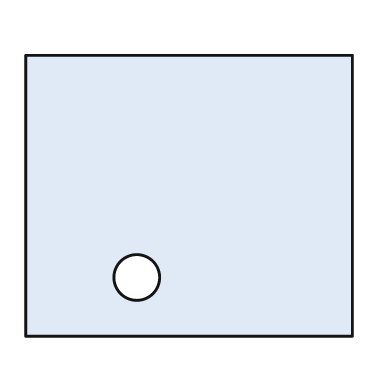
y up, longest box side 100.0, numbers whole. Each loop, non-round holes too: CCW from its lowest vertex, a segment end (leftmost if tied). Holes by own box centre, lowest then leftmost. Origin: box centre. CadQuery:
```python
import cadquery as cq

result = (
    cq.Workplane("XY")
    .moveTo(-50.0, -43.0)
    .lineTo(50.0, -43.0)
    .lineTo(50.0, 43.0)
    .lineTo(-50.0, 43.0)
    .close()
    .moveTo(-16.0, -25.0)
    .circle(7.0)
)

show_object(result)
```